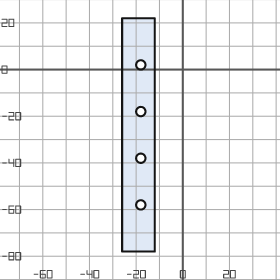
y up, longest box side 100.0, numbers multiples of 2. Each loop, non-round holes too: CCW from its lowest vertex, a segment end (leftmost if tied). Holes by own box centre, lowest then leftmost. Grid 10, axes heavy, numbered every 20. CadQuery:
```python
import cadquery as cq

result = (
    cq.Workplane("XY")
    .moveTo(-26.0, -78.0)
    .lineTo(-12.0, -78.0)
    .lineTo(-12.0, 22.0)
    .lineTo(-26.0, 22.0)
    .close()
    .moveTo(-18.0, -58.0)
    .circle(2.0)
    .moveTo(-18.0, -38.0)
    .circle(2.0)
    .moveTo(-18.0, -18.0)
    .circle(2.0)
    .moveTo(-18.0, 2.0)
    .circle(2.0)
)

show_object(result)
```